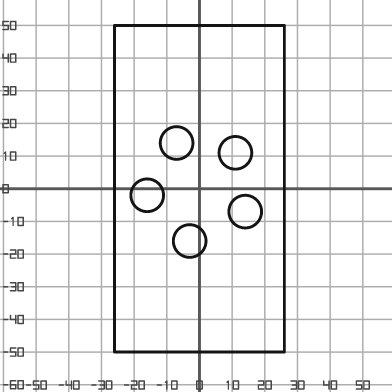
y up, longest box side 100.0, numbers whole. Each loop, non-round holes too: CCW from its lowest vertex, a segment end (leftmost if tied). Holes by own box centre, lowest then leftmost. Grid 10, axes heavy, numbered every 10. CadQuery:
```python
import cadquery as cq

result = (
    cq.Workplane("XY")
    .moveTo(-26.0, -50.0)
    .lineTo(26.0, -50.0)
    .lineTo(26.0, 50.0)
    .lineTo(-26.0, 50.0)
    .close()
    .moveTo(-3.0, -16.0)
    .circle(5.0)
    .moveTo(14.0, -7.0)
    .circle(5.0)
    .moveTo(-16.0, -2.0)
    .circle(5.0)
    .moveTo(11.0, 11.0)
    .circle(5.0)
    .moveTo(-7.0, 14.0)
    .circle(5.0)
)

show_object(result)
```